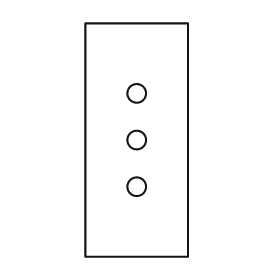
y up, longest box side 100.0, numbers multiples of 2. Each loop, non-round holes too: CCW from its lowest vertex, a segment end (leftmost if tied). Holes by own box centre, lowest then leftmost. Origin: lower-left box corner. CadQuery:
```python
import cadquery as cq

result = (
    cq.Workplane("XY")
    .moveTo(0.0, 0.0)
    .lineTo(44.0, 0.0)
    .lineTo(44.0, 100.0)
    .lineTo(0.0, 100.0)
    .close()
    .moveTo(22.0, 30.0)
    .circle(4.0)
    .moveTo(22.0, 50.0)
    .circle(4.0)
    .moveTo(22.0, 70.0)
    .circle(4.0)
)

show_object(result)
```